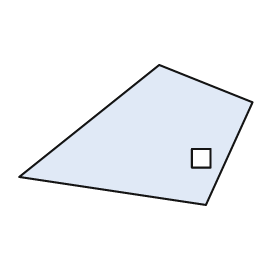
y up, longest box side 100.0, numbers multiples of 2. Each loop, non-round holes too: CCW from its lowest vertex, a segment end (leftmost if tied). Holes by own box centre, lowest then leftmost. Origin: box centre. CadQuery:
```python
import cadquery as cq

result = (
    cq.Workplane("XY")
    .moveTo(30.0, -30.0)
    .lineTo(50.0, 14.0)
    .lineTo(10.0, 30.0)
    .lineTo(-50.0, -18.0)
    .close()
    .moveTo(24.0, -14.0)
    .lineTo(32.0, -14.0)
    .lineTo(32.0, -6.0)
    .lineTo(24.0, -6.0)
    .close()
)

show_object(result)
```